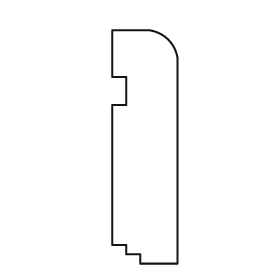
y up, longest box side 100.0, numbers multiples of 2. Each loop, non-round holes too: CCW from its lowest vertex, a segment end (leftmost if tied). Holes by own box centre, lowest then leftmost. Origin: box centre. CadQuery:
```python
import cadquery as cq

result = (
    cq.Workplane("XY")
    .moveTo(-2.0, -50.0)
    .lineTo(14.0, -50.0)
    .lineTo(14.0, 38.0)
    .threePointArc((10.0, 46.0), (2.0, 50.0))
    .lineTo(-14.0, 50.0)
    .lineTo(-14.0, 30.0)
    .lineTo(-8.0, 30.0)
    .lineTo(-8.0, 18.0)
    .lineTo(-14.0, 18.0)
    .lineTo(-14.0, -42.0)
    .lineTo(-8.0, -42.0)
    .lineTo(-8.0, -46.0)
    .lineTo(-2.0, -46.0)
    .close()
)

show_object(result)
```